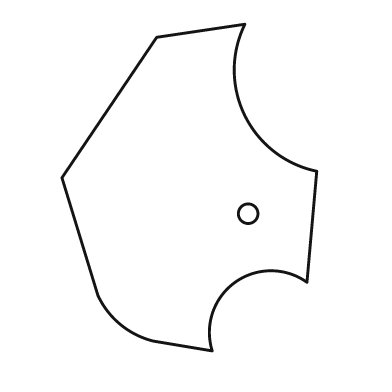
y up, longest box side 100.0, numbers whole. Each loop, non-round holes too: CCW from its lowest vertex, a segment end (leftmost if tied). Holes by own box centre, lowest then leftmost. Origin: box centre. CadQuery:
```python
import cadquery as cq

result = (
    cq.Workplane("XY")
    .moveTo(7.0, -50.0)
    .threePointArc((14.0, -29.0), (36.0, -29.0))
    .lineTo(39.0, 5.0)
    .threePointArc((17.0, 22.0), (17.0, 50.0))
    .lineTo(-10.0, 46.0)
    .lineTo(-39.0, 3.0)
    .lineTo(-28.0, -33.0)
    .threePointArc((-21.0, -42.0), (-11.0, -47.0))
    .close()
    .moveTo(18.0, -8.0)
    .circle(3.0)
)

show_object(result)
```